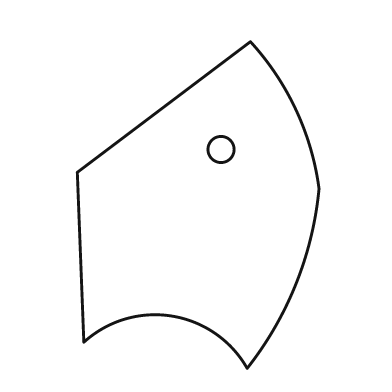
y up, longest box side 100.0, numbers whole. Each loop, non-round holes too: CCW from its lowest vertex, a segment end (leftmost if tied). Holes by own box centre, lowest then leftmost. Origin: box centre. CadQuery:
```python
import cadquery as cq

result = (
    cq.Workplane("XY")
    .moveTo(15.0, -50.0)
    .threePointArc((30.0, -24.0), (37.0, 5.0))
    .threePointArc((30.0, 29.0), (16.0, 50.0))
    .lineTo(-37.0, 10.0)
    .lineTo(-35.0, -42.0)
    .threePointArc((-8.0, -34.0), (15.0, -50.0))
    .close()
    .moveTo(7.0, 17.0)
    .circle(4.0)
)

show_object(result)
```